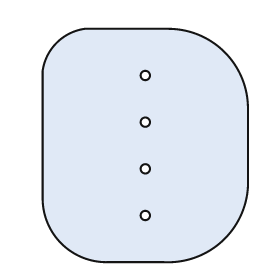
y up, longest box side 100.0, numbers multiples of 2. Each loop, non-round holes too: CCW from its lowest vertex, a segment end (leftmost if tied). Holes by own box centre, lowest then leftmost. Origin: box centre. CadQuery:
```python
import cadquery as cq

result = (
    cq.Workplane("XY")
    .moveTo(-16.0, -50.0)
    .lineTo(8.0, -50.0)
    .threePointArc((34.0, -40.0), (44.0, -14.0))
    .lineTo(44.0, 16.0)
    .threePointArc((34.0, 40.0), (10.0, 50.0))
    .lineTo(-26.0, 50.0)
    .threePointArc((-38.0, 44.0), (-44.0, 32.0))
    .lineTo(-44.0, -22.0)
    .threePointArc((-36.0, -42.0), (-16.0, -50.0))
    .close()
    .moveTo(0.0, -30.0)
    .circle(2.0)
    .moveTo(0.0, -10.0)
    .circle(2.0)
    .moveTo(0.0, 10.0)
    .circle(2.0)
    .moveTo(0.0, 30.0)
    .circle(2.0)
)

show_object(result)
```